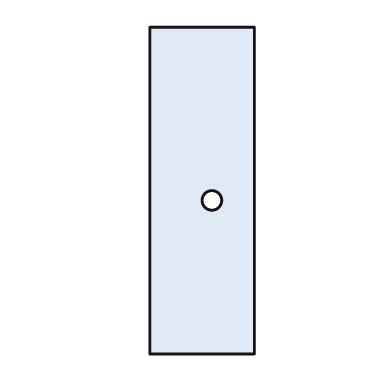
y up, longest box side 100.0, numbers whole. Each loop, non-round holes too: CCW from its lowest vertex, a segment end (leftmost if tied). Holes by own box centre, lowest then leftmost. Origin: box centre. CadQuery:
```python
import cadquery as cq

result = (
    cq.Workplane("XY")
    .moveTo(-16.0, -50.0)
    .lineTo(16.0, -50.0)
    .lineTo(16.0, 50.0)
    .lineTo(-16.0, 50.0)
    .close()
    .moveTo(3.0, -3.0)
    .circle(3.0)
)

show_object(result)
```